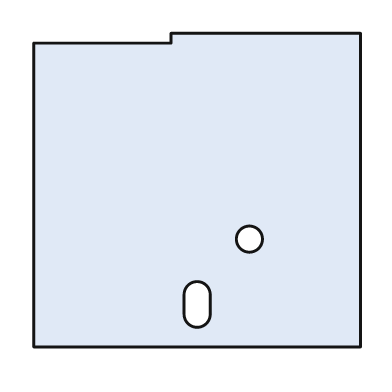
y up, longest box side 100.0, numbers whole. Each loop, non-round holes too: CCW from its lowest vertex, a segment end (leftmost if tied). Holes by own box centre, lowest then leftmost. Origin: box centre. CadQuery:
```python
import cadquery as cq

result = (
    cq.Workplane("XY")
    .moveTo(-50.0, -48.0)
    .lineTo(50.0, -48.0)
    .lineTo(50.0, 48.0)
    .lineTo(-8.0, 48.0)
    .lineTo(-8.0, 45.0)
    .lineTo(-50.0, 45.0)
    .close()
    .moveTo(-4.0, -38.0)
    .threePointArc((0.0, -42.0), (4.0, -38.0))
    .lineTo(4.0, -32.0)
    .threePointArc((0.0, -28.0), (-4.0, -32.0))
    .close()
    .moveTo(16.0, -15.0)
    .circle(4.0)
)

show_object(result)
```